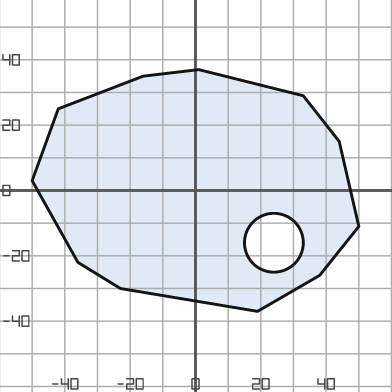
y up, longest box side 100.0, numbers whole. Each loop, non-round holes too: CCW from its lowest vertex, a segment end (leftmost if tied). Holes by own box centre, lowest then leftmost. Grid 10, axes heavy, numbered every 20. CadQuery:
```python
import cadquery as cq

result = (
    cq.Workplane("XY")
    .moveTo(19.0, -37.0)
    .lineTo(38.0, -26.0)
    .lineTo(50.0, -11.0)
    .lineTo(44.0, 15.0)
    .lineTo(33.0, 29.0)
    .lineTo(1.0, 37.0)
    .lineTo(-16.0, 35.0)
    .lineTo(-42.0, 25.0)
    .lineTo(-50.0, 3.0)
    .lineTo(-36.0, -22.0)
    .lineTo(-23.0, -30.0)
    .close()
    .moveTo(24.0, -16.0)
    .circle(9.0)
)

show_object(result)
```